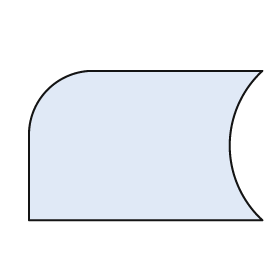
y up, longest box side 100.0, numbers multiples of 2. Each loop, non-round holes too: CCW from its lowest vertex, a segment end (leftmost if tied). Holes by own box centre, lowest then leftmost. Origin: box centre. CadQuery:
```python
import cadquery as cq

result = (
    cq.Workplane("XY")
    .moveTo(-50.0, -32.0)
    .lineTo(50.0, -32.0)
    .threePointArc((36.0, 0.0), (50.0, 32.0))
    .lineTo(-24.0, 32.0)
    .threePointArc((-42.0, 24.0), (-50.0, 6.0))
    .close()
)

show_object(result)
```